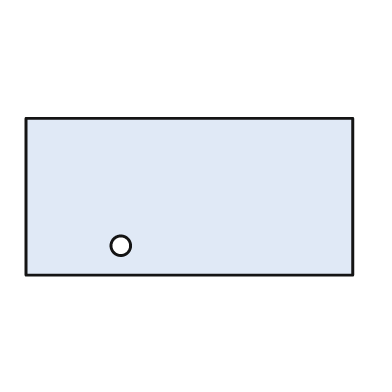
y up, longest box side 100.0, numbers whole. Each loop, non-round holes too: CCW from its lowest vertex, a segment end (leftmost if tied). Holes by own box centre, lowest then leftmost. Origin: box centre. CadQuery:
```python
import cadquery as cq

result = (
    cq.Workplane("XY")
    .moveTo(-50.0, -24.0)
    .lineTo(50.0, -24.0)
    .lineTo(50.0, 24.0)
    .lineTo(-50.0, 24.0)
    .close()
    .moveTo(-21.0, -15.0)
    .circle(3.0)
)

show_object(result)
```